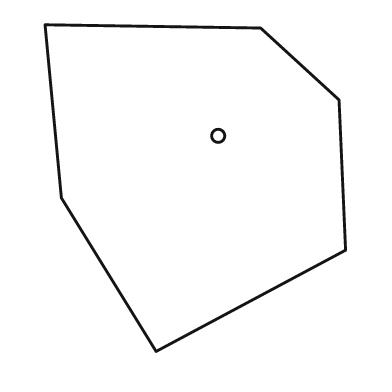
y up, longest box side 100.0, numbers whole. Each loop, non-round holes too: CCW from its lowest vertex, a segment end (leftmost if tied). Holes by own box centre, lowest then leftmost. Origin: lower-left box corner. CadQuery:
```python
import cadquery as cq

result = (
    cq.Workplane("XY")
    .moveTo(34.0, 0.0)
    .lineTo(92.0, 31.0)
    .lineTo(90.0, 77.0)
    .lineTo(66.0, 99.0)
    .lineTo(0.0, 100.0)
    .lineTo(5.0, 47.0)
    .close()
    .moveTo(53.0, 66.0)
    .circle(2.0)
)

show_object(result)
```